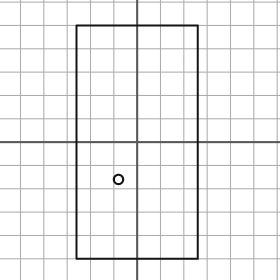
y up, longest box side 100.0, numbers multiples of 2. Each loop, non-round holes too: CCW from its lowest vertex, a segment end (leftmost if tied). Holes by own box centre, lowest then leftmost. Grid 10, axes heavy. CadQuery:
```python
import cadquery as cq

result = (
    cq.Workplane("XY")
    .moveTo(-26.0, -50.0)
    .lineTo(26.0, -50.0)
    .lineTo(26.0, 50.0)
    .lineTo(-26.0, 50.0)
    .close()
    .moveTo(-8.0, -16.0)
    .circle(2.0)
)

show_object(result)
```